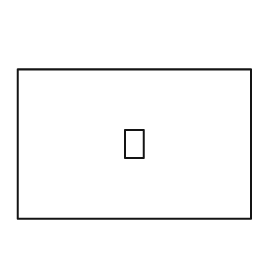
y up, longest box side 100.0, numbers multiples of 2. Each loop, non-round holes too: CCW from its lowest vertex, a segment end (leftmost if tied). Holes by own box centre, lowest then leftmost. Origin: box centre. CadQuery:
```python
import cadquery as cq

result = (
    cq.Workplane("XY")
    .moveTo(-50.0, -32.0)
    .lineTo(50.0, -32.0)
    .lineTo(50.0, 32.0)
    .lineTo(-50.0, 32.0)
    .close()
    .moveTo(-4.0, -6.0)
    .lineTo(4.0, -6.0)
    .lineTo(4.0, 6.0)
    .lineTo(-4.0, 6.0)
    .close()
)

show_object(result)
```